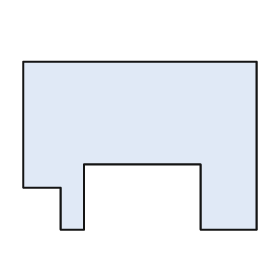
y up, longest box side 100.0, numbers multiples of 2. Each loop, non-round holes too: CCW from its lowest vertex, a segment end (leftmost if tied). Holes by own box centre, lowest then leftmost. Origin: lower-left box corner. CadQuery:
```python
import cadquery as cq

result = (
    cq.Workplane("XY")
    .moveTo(16.0, 0.0)
    .lineTo(26.0, 0.0)
    .lineTo(26.0, 28.0)
    .lineTo(76.0, 28.0)
    .lineTo(76.0, 0.0)
    .lineTo(100.0, 0.0)
    .lineTo(100.0, 72.0)
    .lineTo(0.0, 72.0)
    .lineTo(0.0, 18.0)
    .lineTo(16.0, 18.0)
    .close()
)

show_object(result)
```